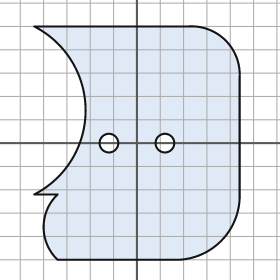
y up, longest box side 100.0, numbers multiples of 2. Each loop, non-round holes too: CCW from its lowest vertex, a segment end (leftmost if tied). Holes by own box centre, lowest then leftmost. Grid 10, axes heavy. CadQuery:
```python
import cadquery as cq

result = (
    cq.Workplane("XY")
    .moveTo(-34.0, -50.0)
    .lineTo(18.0, -50.0)
    .threePointArc((36.0, -42.0), (44.0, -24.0))
    .lineTo(44.0, 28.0)
    .threePointArc((38.0, 44.0), (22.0, 50.0))
    .lineTo(-44.0, 50.0)
    .threePointArc((-22.0, 14.0), (-44.0, -22.0))
    .lineTo(-34.0, -22.0)
    .threePointArc((-40.0, -36.0), (-34.0, -50.0))
    .close()
    .moveTo(-12.0, 0.0)
    .circle(4.0)
    .moveTo(12.0, 0.0)
    .circle(4.0)
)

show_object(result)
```